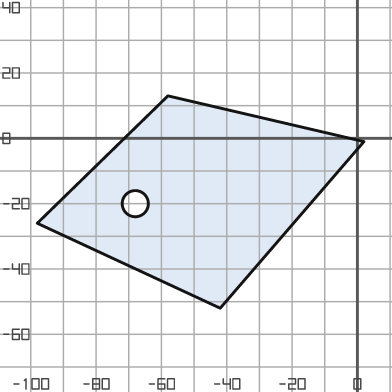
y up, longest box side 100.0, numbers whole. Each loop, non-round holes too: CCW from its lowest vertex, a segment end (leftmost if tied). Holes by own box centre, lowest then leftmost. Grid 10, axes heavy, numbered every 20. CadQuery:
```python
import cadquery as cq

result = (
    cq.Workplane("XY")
    .moveTo(-42.0, -52.0)
    .lineTo(2.0, -1.0)
    .lineTo(-58.0, 13.0)
    .lineTo(-98.0, -26.0)
    .close()
    .moveTo(-68.0, -20.0)
    .circle(4.0)
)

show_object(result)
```